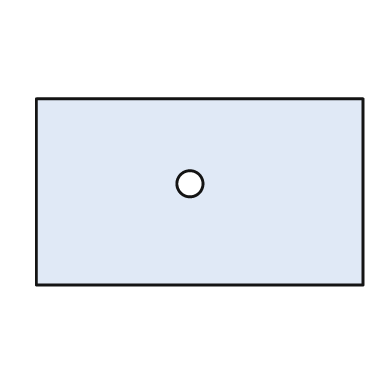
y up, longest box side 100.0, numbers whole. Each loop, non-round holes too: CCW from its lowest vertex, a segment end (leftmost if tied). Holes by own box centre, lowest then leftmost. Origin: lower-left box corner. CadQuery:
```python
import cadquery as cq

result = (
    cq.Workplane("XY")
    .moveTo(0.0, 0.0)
    .lineTo(100.0, 0.0)
    .lineTo(100.0, 57.0)
    .lineTo(0.0, 57.0)
    .close()
    .moveTo(47.0, 31.0)
    .circle(4.0)
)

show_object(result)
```